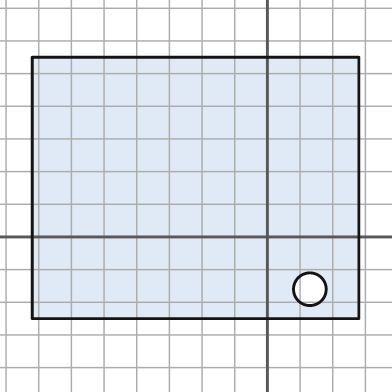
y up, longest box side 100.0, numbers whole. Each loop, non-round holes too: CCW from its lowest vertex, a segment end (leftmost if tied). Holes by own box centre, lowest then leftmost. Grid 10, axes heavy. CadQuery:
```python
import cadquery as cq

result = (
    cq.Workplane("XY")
    .moveTo(-72.0, -25.0)
    .lineTo(28.0, -25.0)
    .lineTo(28.0, 55.0)
    .lineTo(-72.0, 55.0)
    .close()
    .moveTo(13.0, -16.0)
    .circle(5.0)
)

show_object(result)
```